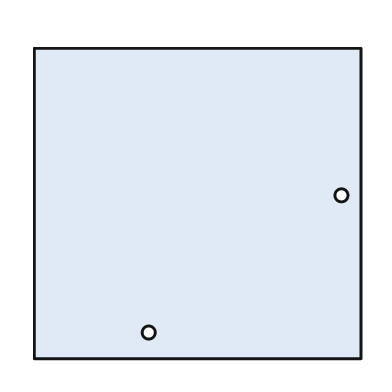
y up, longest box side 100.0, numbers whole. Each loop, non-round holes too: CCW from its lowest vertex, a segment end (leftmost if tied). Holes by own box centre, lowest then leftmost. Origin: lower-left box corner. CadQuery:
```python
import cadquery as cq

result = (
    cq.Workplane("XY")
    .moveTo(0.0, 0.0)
    .lineTo(100.0, 0.0)
    .lineTo(100.0, 95.0)
    .lineTo(0.0, 95.0)
    .close()
    .moveTo(35.0, 8.0)
    .circle(2.0)
    .moveTo(94.0, 50.0)
    .circle(2.0)
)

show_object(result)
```